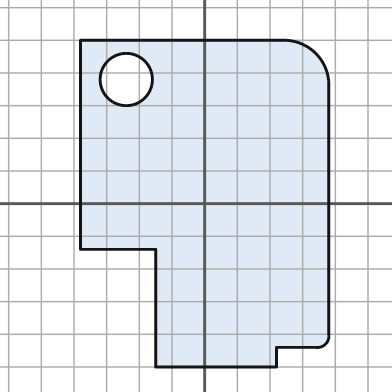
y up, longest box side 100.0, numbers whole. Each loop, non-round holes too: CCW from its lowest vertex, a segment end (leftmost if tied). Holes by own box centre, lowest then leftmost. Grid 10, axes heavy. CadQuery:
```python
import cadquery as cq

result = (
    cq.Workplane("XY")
    .moveTo(-15.0, -50.0)
    .lineTo(22.0, -50.0)
    .lineTo(22.0, -44.0)
    .lineTo(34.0, -44.0)
    .threePointArc((37.0, -43.0), (38.0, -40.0))
    .lineTo(38.0, 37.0)
    .threePointArc((34.0, 46.0), (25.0, 50.0))
    .lineTo(-38.0, 50.0)
    .lineTo(-38.0, -14.0)
    .lineTo(-15.0, -14.0)
    .close()
    .moveTo(-24.0, 38.0)
    .circle(8.0)
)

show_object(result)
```